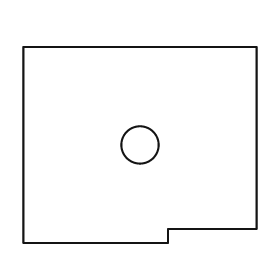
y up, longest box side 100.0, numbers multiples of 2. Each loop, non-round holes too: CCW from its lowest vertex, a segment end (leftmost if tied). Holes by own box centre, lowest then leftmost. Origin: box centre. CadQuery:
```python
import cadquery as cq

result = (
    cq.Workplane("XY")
    .moveTo(-50.0, -42.0)
    .lineTo(12.0, -42.0)
    .lineTo(12.0, -36.0)
    .lineTo(50.0, -36.0)
    .lineTo(50.0, 42.0)
    .lineTo(-50.0, 42.0)
    .close()
    .moveTo(0.0, 0.0)
    .circle(8.0)
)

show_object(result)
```